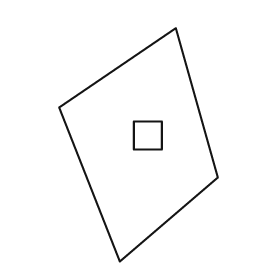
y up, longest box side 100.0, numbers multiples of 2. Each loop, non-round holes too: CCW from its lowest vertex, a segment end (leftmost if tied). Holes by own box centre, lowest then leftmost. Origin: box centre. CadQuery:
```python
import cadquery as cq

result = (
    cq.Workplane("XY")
    .moveTo(-8.0, -50.0)
    .lineTo(34.0, -14.0)
    .lineTo(16.0, 50.0)
    .lineTo(-34.0, 16.0)
    .close()
    .moveTo(-2.0, -2.0)
    .lineTo(10.0, -2.0)
    .lineTo(10.0, 10.0)
    .lineTo(-2.0, 10.0)
    .close()
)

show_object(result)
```